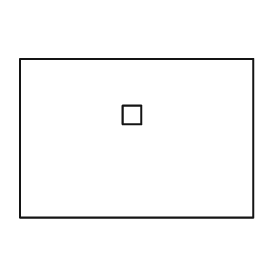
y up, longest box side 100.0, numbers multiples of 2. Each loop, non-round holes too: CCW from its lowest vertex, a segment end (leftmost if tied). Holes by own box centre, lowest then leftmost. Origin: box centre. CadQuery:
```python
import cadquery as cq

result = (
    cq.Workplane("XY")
    .moveTo(-50.0, -34.0)
    .lineTo(50.0, -34.0)
    .lineTo(50.0, 34.0)
    .lineTo(-50.0, 34.0)
    .close()
    .moveTo(-6.0, 6.0)
    .lineTo(2.0, 6.0)
    .lineTo(2.0, 14.0)
    .lineTo(-6.0, 14.0)
    .close()
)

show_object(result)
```